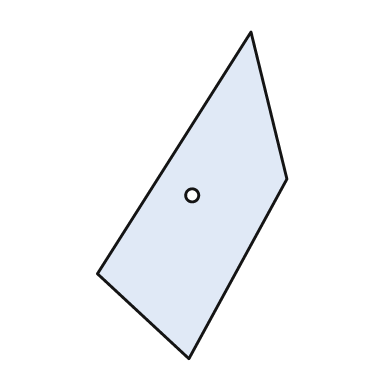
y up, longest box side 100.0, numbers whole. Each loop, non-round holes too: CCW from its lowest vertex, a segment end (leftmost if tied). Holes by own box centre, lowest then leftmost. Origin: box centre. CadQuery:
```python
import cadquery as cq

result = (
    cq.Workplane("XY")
    .moveTo(-1.0, -50.0)
    .lineTo(29.0, 5.0)
    .lineTo(18.0, 50.0)
    .lineTo(-29.0, -24.0)
    .close()
    .moveTo(0.0, 0.0)
    .circle(2.0)
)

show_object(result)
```